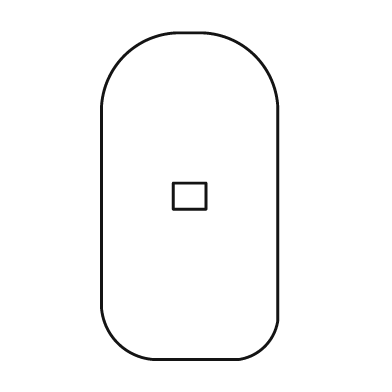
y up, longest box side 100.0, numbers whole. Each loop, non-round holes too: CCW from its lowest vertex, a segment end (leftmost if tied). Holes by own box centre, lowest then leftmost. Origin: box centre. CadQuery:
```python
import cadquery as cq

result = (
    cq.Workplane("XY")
    .moveTo(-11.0, -50.0)
    .lineTo(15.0, -50.0)
    .threePointArc((23.0, -46.0), (27.0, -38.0))
    .lineTo(27.0, 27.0)
    .threePointArc((20.0, 43.0), (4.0, 50.0))
    .lineTo(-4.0, 50.0)
    .threePointArc((-20.0, 43.0), (-27.0, 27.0))
    .lineTo(-27.0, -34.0)
    .threePointArc((-22.0, -45.0), (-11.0, -50.0))
    .close()
    .moveTo(-5.0, -4.0)
    .lineTo(5.0, -4.0)
    .lineTo(5.0, 4.0)
    .lineTo(-5.0, 4.0)
    .close()
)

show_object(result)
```